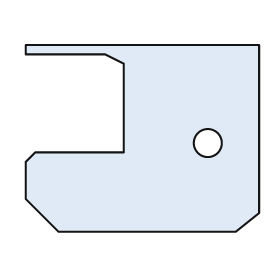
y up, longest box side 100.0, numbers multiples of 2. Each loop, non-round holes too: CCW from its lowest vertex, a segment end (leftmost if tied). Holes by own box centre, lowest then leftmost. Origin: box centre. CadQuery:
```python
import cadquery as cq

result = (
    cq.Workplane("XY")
    .moveTo(-36.0, -40.0)
    .lineTo(40.0, -40.0)
    .lineTo(50.0, -32.0)
    .lineTo(50.0, 40.0)
    .lineTo(-50.0, 40.0)
    .lineTo(-50.0, 36.0)
    .lineTo(-16.0, 36.0)
    .lineTo(-8.0, 32.0)
    .lineTo(-8.0, -6.0)
    .lineTo(-46.0, -6.0)
    .lineTo(-50.0, -10.0)
    .lineTo(-50.0, -26.0)
    .close()
    .moveTo(28.0, -2.0)
    .circle(6.0)
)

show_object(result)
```